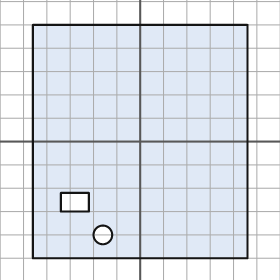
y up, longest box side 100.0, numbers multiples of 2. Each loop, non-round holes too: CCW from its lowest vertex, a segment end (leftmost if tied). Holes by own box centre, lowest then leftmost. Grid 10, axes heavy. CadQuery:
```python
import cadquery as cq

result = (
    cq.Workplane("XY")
    .moveTo(-46.0, -50.0)
    .lineTo(46.0, -50.0)
    .lineTo(46.0, 50.0)
    .lineTo(-46.0, 50.0)
    .close()
    .moveTo(-16.0, -40.0)
    .circle(4.0)
    .moveTo(-34.0, -30.0)
    .lineTo(-22.0, -30.0)
    .lineTo(-22.0, -22.0)
    .lineTo(-34.0, -22.0)
    .close()
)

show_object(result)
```